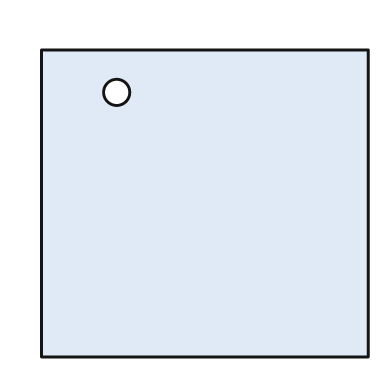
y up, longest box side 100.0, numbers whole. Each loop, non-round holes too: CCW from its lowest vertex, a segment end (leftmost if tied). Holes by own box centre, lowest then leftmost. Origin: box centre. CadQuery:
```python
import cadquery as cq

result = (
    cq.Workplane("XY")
    .moveTo(-50.0, -47.0)
    .lineTo(50.0, -47.0)
    .lineTo(50.0, 47.0)
    .lineTo(-50.0, 47.0)
    .close()
    .moveTo(-27.0, 34.0)
    .circle(4.0)
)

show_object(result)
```